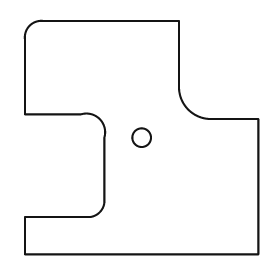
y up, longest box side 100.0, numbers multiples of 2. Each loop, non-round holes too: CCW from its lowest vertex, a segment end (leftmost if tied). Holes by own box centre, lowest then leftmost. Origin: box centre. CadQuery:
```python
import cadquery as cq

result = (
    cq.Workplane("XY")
    .moveTo(-50.0, -50.0)
    .lineTo(50.0, -50.0)
    .lineTo(50.0, 8.0)
    .lineTo(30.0, 8.0)
    .threePointArc((20.0, 12.0), (16.0, 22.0))
    .lineTo(16.0, 50.0)
    .lineTo(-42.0, 50.0)
    .threePointArc((-48.0, 48.0), (-50.0, 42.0))
    .lineTo(-50.0, 10.0)
    .lineTo(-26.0, 10.0)
    .threePointArc((-18.0, 8.0), (-16.0, 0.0))
    .lineTo(-16.0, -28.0)
    .threePointArc((-18.0, -32.0), (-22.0, -34.0))
    .lineTo(-50.0, -34.0)
    .close()
    .moveTo(0.0, 0.0)
    .circle(4.0)
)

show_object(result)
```